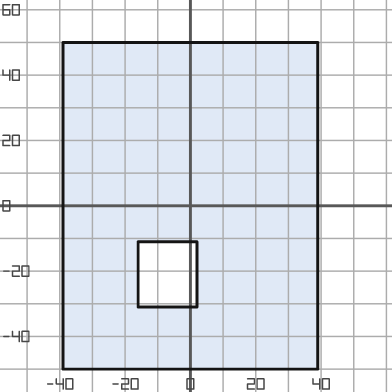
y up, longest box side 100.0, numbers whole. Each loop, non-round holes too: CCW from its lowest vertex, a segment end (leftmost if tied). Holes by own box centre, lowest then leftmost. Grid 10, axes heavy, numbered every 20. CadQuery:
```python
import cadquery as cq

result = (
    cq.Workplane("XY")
    .moveTo(-39.0, -50.0)
    .lineTo(39.0, -50.0)
    .lineTo(39.0, 50.0)
    .lineTo(-39.0, 50.0)
    .close()
    .moveTo(-16.0, -31.0)
    .lineTo(2.0, -31.0)
    .lineTo(2.0, -11.0)
    .lineTo(-16.0, -11.0)
    .close()
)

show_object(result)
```